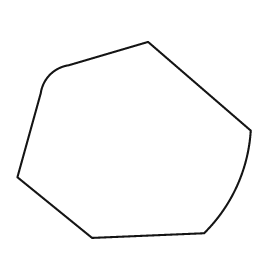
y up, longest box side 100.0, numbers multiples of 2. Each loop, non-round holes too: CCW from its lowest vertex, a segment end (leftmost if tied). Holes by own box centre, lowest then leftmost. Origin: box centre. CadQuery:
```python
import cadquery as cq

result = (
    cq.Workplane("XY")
    .moveTo(-18.0, -42.0)
    .lineTo(30.0, -40.0)
    .threePointArc((44.0, -20.0), (50.0, 4.0))
    .lineTo(6.0, 42.0)
    .lineTo(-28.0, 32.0)
    .threePointArc((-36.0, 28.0), (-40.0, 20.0))
    .lineTo(-50.0, -16.0)
    .close()
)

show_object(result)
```